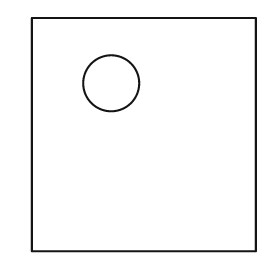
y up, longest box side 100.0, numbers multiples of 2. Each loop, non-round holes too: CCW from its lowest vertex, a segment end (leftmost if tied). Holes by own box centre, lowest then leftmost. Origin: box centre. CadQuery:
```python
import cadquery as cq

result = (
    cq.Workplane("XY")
    .moveTo(-48.0, -50.0)
    .lineTo(48.0, -50.0)
    .lineTo(48.0, 50.0)
    .lineTo(-48.0, 50.0)
    .close()
    .moveTo(-14.0, 22.0)
    .circle(12.0)
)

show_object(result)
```